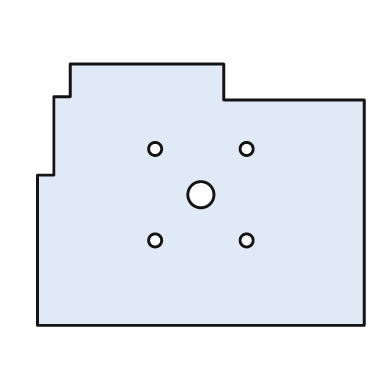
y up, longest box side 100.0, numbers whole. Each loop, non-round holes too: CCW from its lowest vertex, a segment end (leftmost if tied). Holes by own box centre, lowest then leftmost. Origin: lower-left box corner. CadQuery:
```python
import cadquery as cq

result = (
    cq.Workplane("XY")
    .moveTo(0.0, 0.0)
    .lineTo(100.0, 0.0)
    .lineTo(100.0, 69.0)
    .lineTo(57.0, 69.0)
    .lineTo(57.0, 80.0)
    .lineTo(10.0, 80.0)
    .lineTo(10.0, 70.0)
    .lineTo(5.0, 70.0)
    .lineTo(5.0, 46.0)
    .lineTo(0.0, 46.0)
    .close()
    .moveTo(36.0, 26.0)
    .circle(2.0)
    .moveTo(64.0, 26.0)
    .circle(2.0)
    .moveTo(50.0, 40.0)
    .circle(4.0)
    .moveTo(36.0, 54.0)
    .circle(2.0)
    .moveTo(64.0, 54.0)
    .circle(2.0)
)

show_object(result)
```